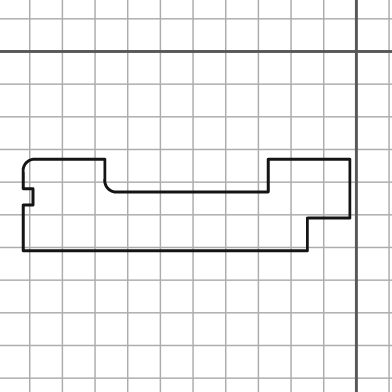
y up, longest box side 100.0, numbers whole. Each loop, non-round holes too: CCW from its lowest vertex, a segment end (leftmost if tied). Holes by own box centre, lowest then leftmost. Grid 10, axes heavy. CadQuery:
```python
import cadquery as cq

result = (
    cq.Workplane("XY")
    .moveTo(-102.0, -61.0)
    .lineTo(-15.0, -61.0)
    .lineTo(-15.0, -51.0)
    .lineTo(-2.0, -51.0)
    .lineTo(-2.0, -33.0)
    .lineTo(-27.0, -33.0)
    .lineTo(-27.0, -43.0)
    .lineTo(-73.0, -43.0)
    .threePointArc((-76.0, -42.0), (-77.0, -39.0))
    .lineTo(-77.0, -33.0)
    .lineTo(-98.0, -33.0)
    .threePointArc((-101.0, -34.0), (-102.0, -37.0))
    .lineTo(-102.0, -42.0)
    .lineTo(-99.0, -42.0)
    .lineTo(-99.0, -47.0)
    .lineTo(-102.0, -47.0)
    .close()
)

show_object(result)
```